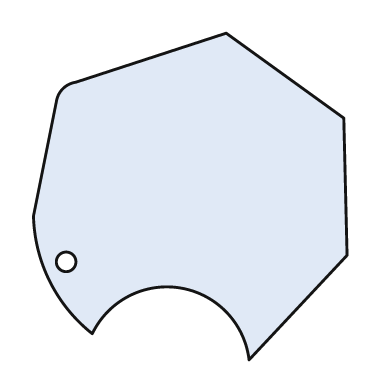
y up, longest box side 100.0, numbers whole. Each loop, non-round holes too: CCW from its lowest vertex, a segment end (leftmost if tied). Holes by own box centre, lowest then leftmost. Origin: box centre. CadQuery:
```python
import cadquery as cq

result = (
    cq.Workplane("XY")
    .moveTo(18.0, -50.0)
    .lineTo(48.0, -18.0)
    .lineTo(47.0, 24.0)
    .lineTo(11.0, 50.0)
    .lineTo(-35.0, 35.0)
    .threePointArc((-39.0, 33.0), (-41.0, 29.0))
    .lineTo(-48.0, -6.0)
    .threePointArc((-43.0, -26.0), (-30.0, -42.0))
    .threePointArc((-3.0, -28.0), (18.0, -50.0))
    .close()
    .moveTo(-38.0, -20.0)
    .circle(3.0)
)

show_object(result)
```